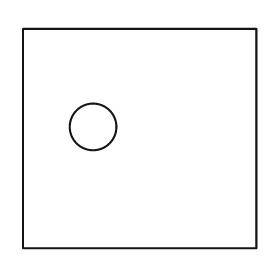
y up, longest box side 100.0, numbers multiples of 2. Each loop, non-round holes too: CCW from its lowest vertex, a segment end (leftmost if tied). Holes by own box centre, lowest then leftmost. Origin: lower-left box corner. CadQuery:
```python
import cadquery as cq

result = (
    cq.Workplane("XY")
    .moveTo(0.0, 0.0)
    .lineTo(100.0, 0.0)
    .lineTo(100.0, 94.0)
    .lineTo(0.0, 94.0)
    .close()
    .moveTo(30.0, 52.0)
    .circle(10.0)
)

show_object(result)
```